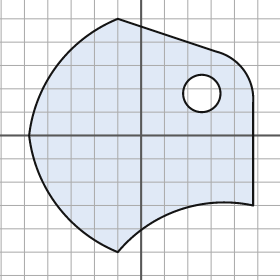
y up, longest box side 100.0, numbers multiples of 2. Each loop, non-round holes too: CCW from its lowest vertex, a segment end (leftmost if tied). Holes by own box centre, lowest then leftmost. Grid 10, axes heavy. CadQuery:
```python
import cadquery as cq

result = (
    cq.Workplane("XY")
    .moveTo(-10.0, -50.0)
    .threePointArc((16.0, -32.0), (48.0, -30.0))
    .lineTo(48.0, 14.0)
    .threePointArc((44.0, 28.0), (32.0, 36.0))
    .lineTo(-10.0, 50.0)
    .threePointArc((-36.0, 30.0), (-48.0, 0.0))
    .threePointArc((-36.0, -30.0), (-10.0, -50.0))
    .close()
    .moveTo(26.0, 18.0)
    .circle(8.0)
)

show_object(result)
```